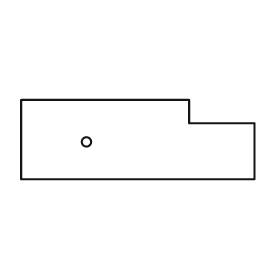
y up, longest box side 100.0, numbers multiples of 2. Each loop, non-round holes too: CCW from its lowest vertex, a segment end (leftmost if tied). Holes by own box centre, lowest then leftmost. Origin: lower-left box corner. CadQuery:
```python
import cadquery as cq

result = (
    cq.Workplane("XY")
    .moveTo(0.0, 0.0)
    .lineTo(100.0, 0.0)
    .lineTo(100.0, 24.0)
    .lineTo(72.0, 24.0)
    .lineTo(72.0, 34.0)
    .lineTo(0.0, 34.0)
    .close()
    .moveTo(28.0, 16.0)
    .circle(2.0)
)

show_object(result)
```